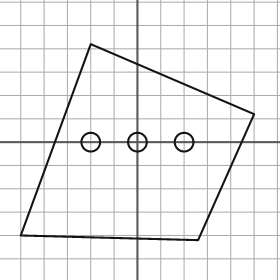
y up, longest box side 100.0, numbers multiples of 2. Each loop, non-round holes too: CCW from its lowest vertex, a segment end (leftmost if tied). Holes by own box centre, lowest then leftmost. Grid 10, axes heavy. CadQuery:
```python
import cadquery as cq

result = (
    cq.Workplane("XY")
    .moveTo(26.0, -42.0)
    .lineTo(50.0, 12.0)
    .lineTo(-20.0, 42.0)
    .lineTo(-50.0, -40.0)
    .close()
    .moveTo(-20.0, 0.0)
    .circle(4.0)
    .moveTo(0.0, 0.0)
    .circle(4.0)
    .moveTo(20.0, 0.0)
    .circle(4.0)
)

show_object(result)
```